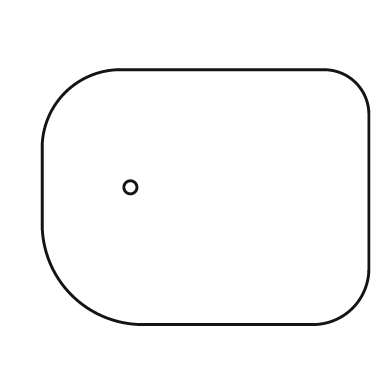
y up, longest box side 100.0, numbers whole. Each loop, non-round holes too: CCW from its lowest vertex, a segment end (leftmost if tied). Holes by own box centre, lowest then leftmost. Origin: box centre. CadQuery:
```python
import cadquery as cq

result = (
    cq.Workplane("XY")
    .moveTo(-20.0, -39.0)
    .lineTo(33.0, -39.0)
    .threePointArc((45.0, -34.0), (50.0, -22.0))
    .lineTo(50.0, 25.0)
    .threePointArc((46.0, 35.0), (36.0, 39.0))
    .lineTo(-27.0, 39.0)
    .threePointArc((-43.0, 32.0), (-50.0, 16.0))
    .lineTo(-50.0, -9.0)
    .threePointArc((-41.0, -30.0), (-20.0, -39.0))
    .close()
    .moveTo(-23.0, 3.0)
    .circle(2.0)
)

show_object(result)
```